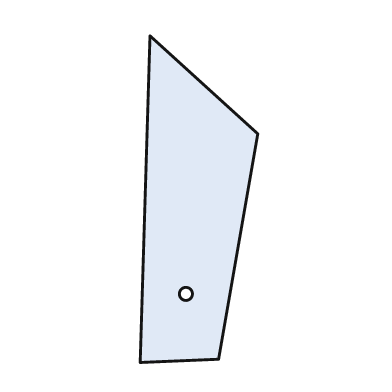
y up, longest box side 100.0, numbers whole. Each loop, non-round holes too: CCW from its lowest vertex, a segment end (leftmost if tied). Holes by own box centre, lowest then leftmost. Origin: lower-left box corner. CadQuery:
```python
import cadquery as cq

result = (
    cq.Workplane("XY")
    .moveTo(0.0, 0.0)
    .lineTo(24.0, 1.0)
    .lineTo(36.0, 70.0)
    .lineTo(3.0, 100.0)
    .close()
    .moveTo(14.0, 21.0)
    .circle(2.0)
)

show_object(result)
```